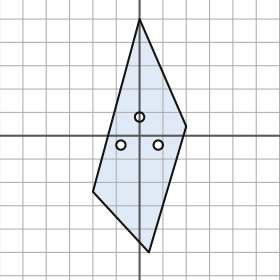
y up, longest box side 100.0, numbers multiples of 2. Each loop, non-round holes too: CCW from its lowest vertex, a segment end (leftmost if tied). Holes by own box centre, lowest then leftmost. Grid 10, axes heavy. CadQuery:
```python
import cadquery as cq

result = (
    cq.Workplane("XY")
    .moveTo(4.0, -50.0)
    .lineTo(20.0, 4.0)
    .lineTo(0.0, 50.0)
    .lineTo(-20.0, -24.0)
    .close()
    .moveTo(-8.0, -4.0)
    .circle(2.0)
    .moveTo(8.0, -4.0)
    .circle(2.0)
    .moveTo(0.0, 8.0)
    .circle(2.0)
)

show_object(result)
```